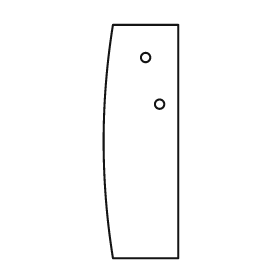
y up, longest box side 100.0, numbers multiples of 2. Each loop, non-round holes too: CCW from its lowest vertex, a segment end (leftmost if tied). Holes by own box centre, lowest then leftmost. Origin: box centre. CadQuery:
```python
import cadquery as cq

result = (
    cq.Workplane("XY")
    .moveTo(-12.0, -50.0)
    .lineTo(16.0, -50.0)
    .lineTo(16.0, 50.0)
    .lineTo(-12.0, 50.0)
    .threePointArc((-16.0, 0.0), (-12.0, -50.0))
    .close()
    .moveTo(8.0, 16.0)
    .circle(2.0)
    .moveTo(2.0, 36.0)
    .circle(2.0)
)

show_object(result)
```